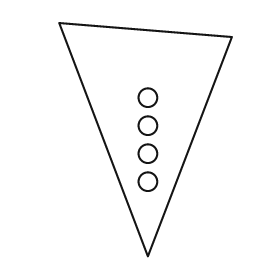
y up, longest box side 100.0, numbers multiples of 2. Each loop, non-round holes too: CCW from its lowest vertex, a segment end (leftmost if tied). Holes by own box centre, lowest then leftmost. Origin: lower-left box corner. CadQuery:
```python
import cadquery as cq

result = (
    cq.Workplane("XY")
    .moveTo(38.0, 0.0)
    .lineTo(74.0, 94.0)
    .lineTo(0.0, 100.0)
    .close()
    .moveTo(38.0, 32.0)
    .circle(4.0)
    .moveTo(38.0, 44.0)
    .circle(4.0)
    .moveTo(38.0, 56.0)
    .circle(4.0)
    .moveTo(38.0, 68.0)
    .circle(4.0)
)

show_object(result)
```